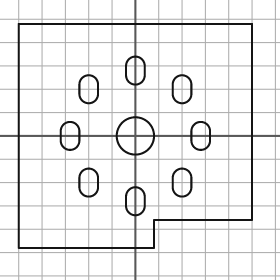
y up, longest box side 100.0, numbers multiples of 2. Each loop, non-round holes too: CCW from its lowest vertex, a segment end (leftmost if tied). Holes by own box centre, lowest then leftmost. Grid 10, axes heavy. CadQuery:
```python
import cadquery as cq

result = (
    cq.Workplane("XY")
    .moveTo(-50.0, -48.0)
    .lineTo(8.0, -48.0)
    .lineTo(8.0, -36.0)
    .lineTo(50.0, -36.0)
    .lineTo(50.0, 48.0)
    .lineTo(-50.0, 48.0)
    .close()
    .moveTo(-4.0, -30.0)
    .threePointArc((0.0, -34.0), (4.0, -30.0))
    .lineTo(4.0, -26.0)
    .threePointArc((0.0, -22.0), (-4.0, -26.0))
    .close()
    .moveTo(-24.0, -22.0)
    .threePointArc((-20.0, -26.0), (-16.0, -22.0))
    .lineTo(-16.0, -18.0)
    .threePointArc((-20.0, -14.0), (-24.0, -18.0))
    .close()
    .moveTo(16.0, -22.0)
    .threePointArc((20.0, -26.0), (24.0, -22.0))
    .lineTo(24.0, -18.0)
    .threePointArc((20.0, -14.0), (16.0, -18.0))
    .close()
    .moveTo(-32.0, -2.0)
    .threePointArc((-28.0, -6.0), (-24.0, -2.0))
    .lineTo(-24.0, 2.0)
    .threePointArc((-28.0, 6.0), (-32.0, 2.0))
    .close()
    .moveTo(0.0, 0.0)
    .circle(8.0)
    .moveTo(24.0, -2.0)
    .threePointArc((28.0, -6.0), (32.0, -2.0))
    .lineTo(32.0, 2.0)
    .threePointArc((28.0, 6.0), (24.0, 2.0))
    .close()
    .moveTo(-24.0, 18.0)
    .threePointArc((-20.0, 14.0), (-16.0, 18.0))
    .lineTo(-16.0, 22.0)
    .threePointArc((-20.0, 26.0), (-24.0, 22.0))
    .close()
    .moveTo(16.0, 18.0)
    .threePointArc((20.0, 14.0), (24.0, 18.0))
    .lineTo(24.0, 22.0)
    .threePointArc((20.0, 26.0), (16.0, 22.0))
    .close()
    .moveTo(-4.0, 26.0)
    .threePointArc((0.0, 22.0), (4.0, 26.0))
    .lineTo(4.0, 30.0)
    .threePointArc((0.0, 34.0), (-4.0, 30.0))
    .close()
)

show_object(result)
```